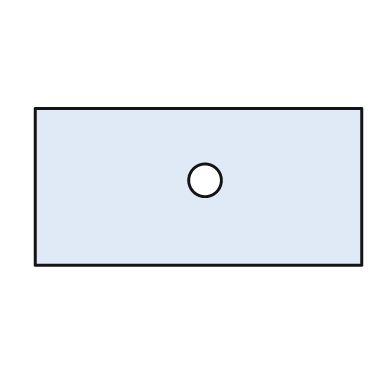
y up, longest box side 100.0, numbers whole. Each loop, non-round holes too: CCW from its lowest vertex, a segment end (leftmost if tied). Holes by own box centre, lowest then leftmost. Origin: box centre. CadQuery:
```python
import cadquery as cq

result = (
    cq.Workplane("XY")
    .moveTo(-50.0, -24.0)
    .lineTo(50.0, -24.0)
    .lineTo(50.0, 24.0)
    .lineTo(-50.0, 24.0)
    .close()
    .moveTo(2.0, 2.0)
    .circle(5.0)
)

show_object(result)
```